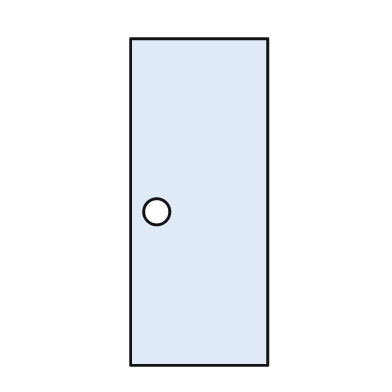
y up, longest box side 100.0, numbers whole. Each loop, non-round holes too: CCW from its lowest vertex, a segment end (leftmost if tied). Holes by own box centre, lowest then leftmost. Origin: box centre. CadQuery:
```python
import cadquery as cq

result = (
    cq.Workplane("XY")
    .moveTo(-21.0, -50.0)
    .lineTo(21.0, -50.0)
    .lineTo(21.0, 50.0)
    .lineTo(-21.0, 50.0)
    .close()
    .moveTo(-13.0, -3.0)
    .circle(4.0)
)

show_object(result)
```